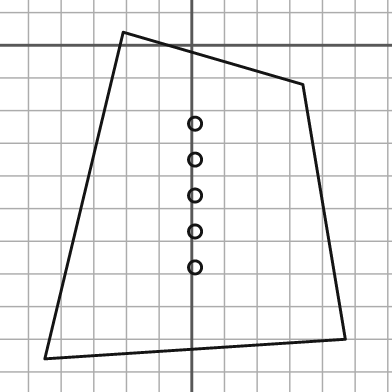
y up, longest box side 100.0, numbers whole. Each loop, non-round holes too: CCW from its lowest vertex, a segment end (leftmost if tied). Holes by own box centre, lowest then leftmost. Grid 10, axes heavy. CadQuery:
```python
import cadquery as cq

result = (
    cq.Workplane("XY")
    .moveTo(-45.0, -96.0)
    .lineTo(47.0, -90.0)
    .lineTo(34.0, -12.0)
    .lineTo(-21.0, 4.0)
    .close()
    .moveTo(1.0, -68.0)
    .circle(2.0)
    .moveTo(1.0, -57.0)
    .circle(2.0)
    .moveTo(1.0, -46.0)
    .circle(2.0)
    .moveTo(1.0, -35.0)
    .circle(2.0)
    .moveTo(1.0, -24.0)
    .circle(2.0)
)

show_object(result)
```